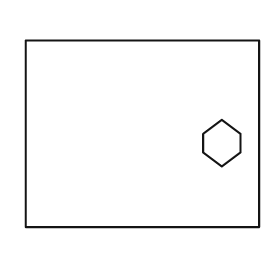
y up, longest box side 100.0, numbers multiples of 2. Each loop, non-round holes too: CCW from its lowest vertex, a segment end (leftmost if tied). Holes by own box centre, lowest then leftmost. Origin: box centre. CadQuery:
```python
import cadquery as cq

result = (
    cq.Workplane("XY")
    .moveTo(-50.0, -40.0)
    .lineTo(50.0, -40.0)
    .lineTo(50.0, 40.0)
    .lineTo(-50.0, 40.0)
    .close()
    .moveTo(34.0, -14.0)
    .lineTo(42.0, -8.0)
    .lineTo(42.0, 0.0)
    .lineTo(34.0, 6.0)
    .lineTo(26.0, 0.0)
    .lineTo(26.0, -8.0)
    .close()
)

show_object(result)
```